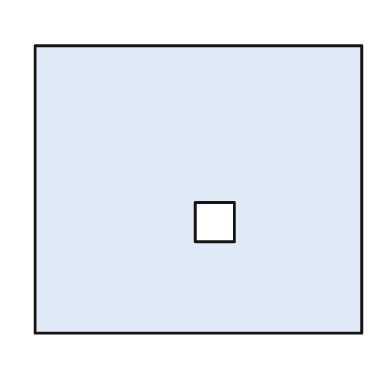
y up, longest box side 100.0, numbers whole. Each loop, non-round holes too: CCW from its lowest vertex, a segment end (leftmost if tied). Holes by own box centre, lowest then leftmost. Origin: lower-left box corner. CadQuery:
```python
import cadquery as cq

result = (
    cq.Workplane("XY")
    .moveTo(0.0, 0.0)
    .lineTo(100.0, 0.0)
    .lineTo(100.0, 88.0)
    .lineTo(0.0, 88.0)
    .close()
    .moveTo(49.0, 28.0)
    .lineTo(61.0, 28.0)
    .lineTo(61.0, 40.0)
    .lineTo(49.0, 40.0)
    .close()
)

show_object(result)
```